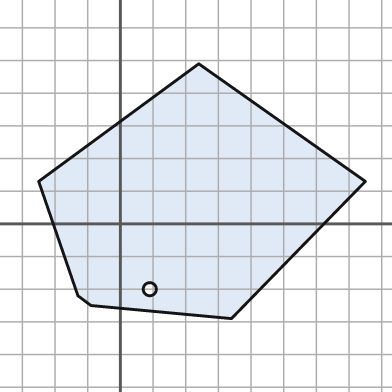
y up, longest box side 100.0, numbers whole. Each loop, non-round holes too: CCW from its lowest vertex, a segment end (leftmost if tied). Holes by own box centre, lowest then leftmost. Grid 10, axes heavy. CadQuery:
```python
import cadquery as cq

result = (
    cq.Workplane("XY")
    .moveTo(34.0, -29.0)
    .lineTo(75.0, 13.0)
    .lineTo(24.0, 49.0)
    .lineTo(-25.0, 13.0)
    .lineTo(-13.0, -22.0)
    .lineTo(-9.0, -25.0)
    .close()
    .moveTo(9.0, -20.0)
    .circle(2.0)
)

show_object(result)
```